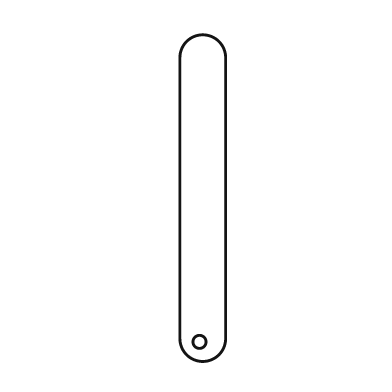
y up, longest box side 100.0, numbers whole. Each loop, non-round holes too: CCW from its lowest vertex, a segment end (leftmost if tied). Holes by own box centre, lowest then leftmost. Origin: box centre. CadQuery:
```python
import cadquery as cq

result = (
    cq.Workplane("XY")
    .moveTo(-7.0, -43.0)
    .threePointArc((0.0, -50.0), (7.0, -43.0))
    .lineTo(7.0, 43.0)
    .threePointArc((0.0, 50.0), (-7.0, 43.0))
    .close()
    .moveTo(-1.0, -44.0)
    .circle(2.0)
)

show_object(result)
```